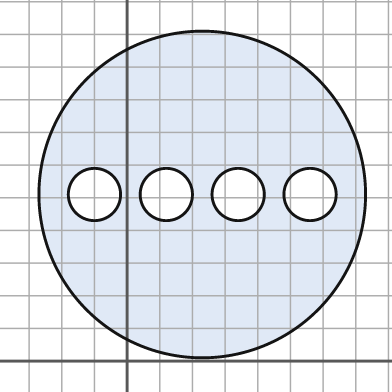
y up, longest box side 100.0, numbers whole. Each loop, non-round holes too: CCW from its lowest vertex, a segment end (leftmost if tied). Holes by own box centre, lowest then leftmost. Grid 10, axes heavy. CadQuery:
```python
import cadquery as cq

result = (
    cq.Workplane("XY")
    .moveTo(23.0, 51.0)
    .circle(50.0)
    .moveTo(-10.0, 51.0)
    .circle(8.0)
    .moveTo(12.0, 51.0)
    .circle(8.0)
    .moveTo(34.0, 51.0)
    .circle(8.0)
    .moveTo(56.0, 51.0)
    .circle(8.0)
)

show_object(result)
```